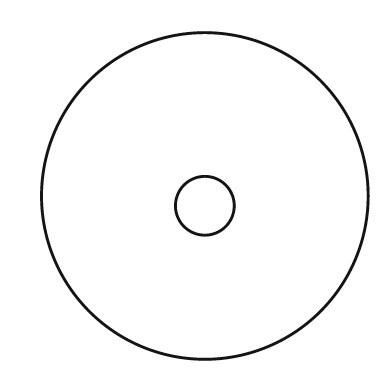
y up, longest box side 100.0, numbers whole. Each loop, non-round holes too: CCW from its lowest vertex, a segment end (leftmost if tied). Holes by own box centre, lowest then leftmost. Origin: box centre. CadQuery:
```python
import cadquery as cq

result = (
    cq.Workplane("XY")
    .moveTo(0.0, 0.0)
    .circle(50.0)
    .moveTo(0.0, -3.0)
    .circle(9.0)
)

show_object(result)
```